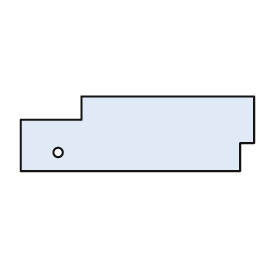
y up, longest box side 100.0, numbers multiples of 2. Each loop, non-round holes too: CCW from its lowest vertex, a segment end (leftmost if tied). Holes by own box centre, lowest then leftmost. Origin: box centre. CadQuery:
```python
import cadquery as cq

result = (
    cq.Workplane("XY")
    .moveTo(-50.0, -16.0)
    .lineTo(44.0, -16.0)
    .lineTo(44.0, -4.0)
    .lineTo(50.0, -4.0)
    .lineTo(50.0, 16.0)
    .lineTo(-24.0, 16.0)
    .lineTo(-24.0, 6.0)
    .lineTo(-50.0, 6.0)
    .close()
    .moveTo(-34.0, -8.0)
    .circle(2.0)
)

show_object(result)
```